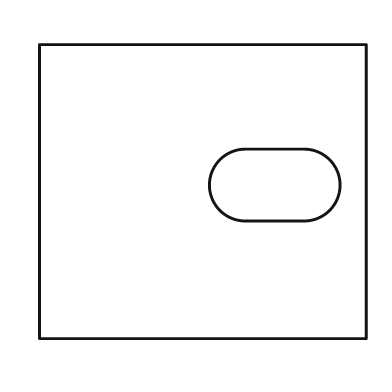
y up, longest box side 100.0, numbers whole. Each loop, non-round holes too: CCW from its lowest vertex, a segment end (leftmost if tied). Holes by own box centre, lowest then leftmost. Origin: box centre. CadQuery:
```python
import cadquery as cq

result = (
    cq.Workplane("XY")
    .moveTo(-50.0, -45.0)
    .lineTo(50.0, -45.0)
    .lineTo(50.0, 45.0)
    .lineTo(-50.0, 45.0)
    .close()
    .moveTo(13.0, -9.0)
    .lineTo(31.0, -9.0)
    .threePointArc((42.0, 2.0), (31.0, 13.0))
    .lineTo(13.0, 13.0)
    .threePointArc((2.0, 2.0), (13.0, -9.0))
    .close()
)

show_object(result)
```